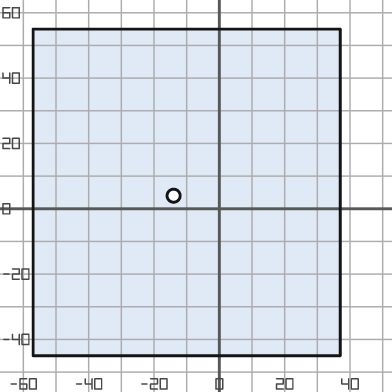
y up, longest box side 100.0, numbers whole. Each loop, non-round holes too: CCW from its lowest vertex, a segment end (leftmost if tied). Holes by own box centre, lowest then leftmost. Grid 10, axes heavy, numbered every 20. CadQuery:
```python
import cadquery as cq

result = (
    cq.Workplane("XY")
    .moveTo(-57.0, -45.0)
    .lineTo(37.0, -45.0)
    .lineTo(37.0, 55.0)
    .lineTo(-57.0, 55.0)
    .close()
    .moveTo(-14.0, 4.0)
    .circle(2.0)
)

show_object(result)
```